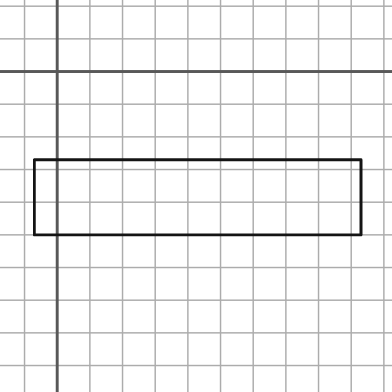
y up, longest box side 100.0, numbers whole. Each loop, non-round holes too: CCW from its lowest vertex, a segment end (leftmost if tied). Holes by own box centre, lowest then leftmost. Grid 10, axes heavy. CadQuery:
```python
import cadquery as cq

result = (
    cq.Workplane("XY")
    .moveTo(-7.0, -50.0)
    .lineTo(93.0, -50.0)
    .lineTo(93.0, -27.0)
    .lineTo(-7.0, -27.0)
    .close()
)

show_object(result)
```